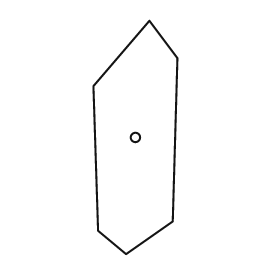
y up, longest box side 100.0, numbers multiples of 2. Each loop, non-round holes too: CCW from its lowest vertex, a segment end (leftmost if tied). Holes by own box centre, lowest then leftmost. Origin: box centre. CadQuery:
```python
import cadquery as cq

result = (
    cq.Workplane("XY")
    .moveTo(-4.0, -50.0)
    .lineTo(16.0, -36.0)
    .lineTo(18.0, 34.0)
    .lineTo(6.0, 50.0)
    .lineTo(-18.0, 22.0)
    .lineTo(-16.0, -40.0)
    .close()
    .moveTo(0.0, 0.0)
    .circle(2.0)
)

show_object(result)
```